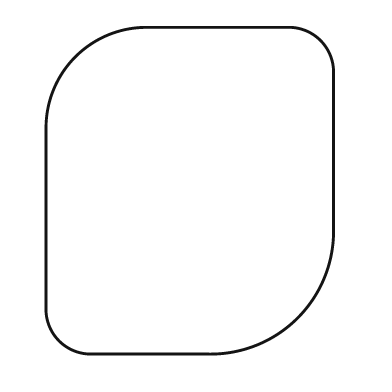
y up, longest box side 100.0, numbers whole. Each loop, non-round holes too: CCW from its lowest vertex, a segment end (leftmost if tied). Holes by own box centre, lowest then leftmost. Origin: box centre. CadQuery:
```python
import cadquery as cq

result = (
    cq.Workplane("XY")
    .moveTo(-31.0, -50.0)
    .lineTo(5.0, -50.0)
    .threePointArc((33.0, -39.0), (44.0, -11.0))
    .lineTo(44.0, 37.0)
    .threePointArc((40.0, 46.0), (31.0, 50.0))
    .lineTo(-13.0, 50.0)
    .threePointArc((-35.0, 41.0), (-44.0, 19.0))
    .lineTo(-44.0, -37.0)
    .threePointArc((-40.0, -46.0), (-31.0, -50.0))
    .close()
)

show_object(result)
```